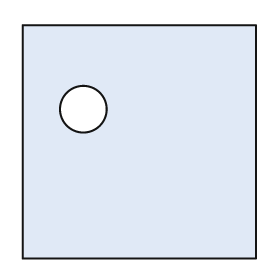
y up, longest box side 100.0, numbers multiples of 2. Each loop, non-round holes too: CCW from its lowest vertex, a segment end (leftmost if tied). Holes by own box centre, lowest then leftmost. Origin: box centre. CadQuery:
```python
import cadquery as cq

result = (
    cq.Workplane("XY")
    .moveTo(-50.0, -50.0)
    .lineTo(50.0, -50.0)
    .lineTo(50.0, 50.0)
    .lineTo(-50.0, 50.0)
    .close()
    .moveTo(-24.0, 14.0)
    .circle(10.0)
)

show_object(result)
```